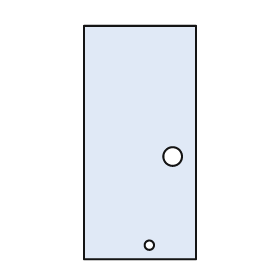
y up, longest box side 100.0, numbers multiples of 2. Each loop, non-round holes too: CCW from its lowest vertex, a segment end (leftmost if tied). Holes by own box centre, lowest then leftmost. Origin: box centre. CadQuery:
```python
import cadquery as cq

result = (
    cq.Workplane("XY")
    .moveTo(-24.0, -50.0)
    .lineTo(24.0, -50.0)
    .lineTo(24.0, 50.0)
    .lineTo(-24.0, 50.0)
    .close()
    .moveTo(4.0, -44.0)
    .circle(2.0)
    .moveTo(14.0, -6.0)
    .circle(4.0)
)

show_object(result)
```